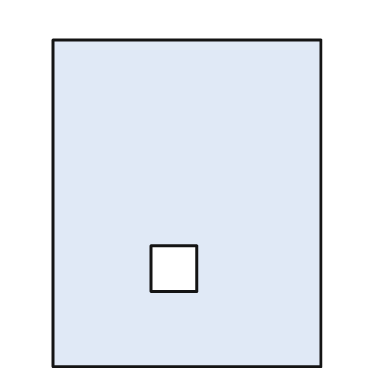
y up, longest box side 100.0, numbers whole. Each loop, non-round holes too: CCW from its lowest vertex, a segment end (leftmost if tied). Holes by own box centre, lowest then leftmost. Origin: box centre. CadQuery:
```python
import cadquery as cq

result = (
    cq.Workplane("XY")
    .moveTo(-41.0, -50.0)
    .lineTo(41.0, -50.0)
    .lineTo(41.0, 50.0)
    .lineTo(-41.0, 50.0)
    .close()
    .moveTo(-11.0, -27.0)
    .lineTo(3.0, -27.0)
    .lineTo(3.0, -13.0)
    .lineTo(-11.0, -13.0)
    .close()
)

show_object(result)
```